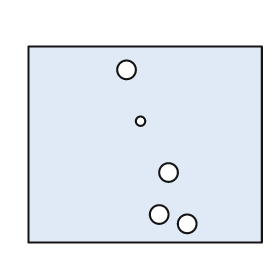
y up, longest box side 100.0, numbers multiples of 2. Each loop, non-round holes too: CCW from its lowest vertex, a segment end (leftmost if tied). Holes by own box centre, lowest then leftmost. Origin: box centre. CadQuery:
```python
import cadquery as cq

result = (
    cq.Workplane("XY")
    .moveTo(-50.0, -42.0)
    .lineTo(50.0, -42.0)
    .lineTo(50.0, 42.0)
    .lineTo(-50.0, 42.0)
    .close()
    .moveTo(18.0, -34.0)
    .circle(4.0)
    .moveTo(6.0, -30.0)
    .circle(4.0)
    .moveTo(10.0, -12.0)
    .circle(4.0)
    .moveTo(-2.0, 10.0)
    .circle(2.0)
    .moveTo(-8.0, 32.0)
    .circle(4.0)
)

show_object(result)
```